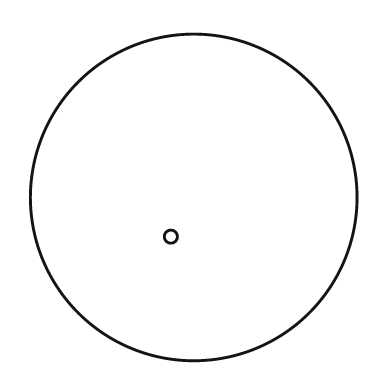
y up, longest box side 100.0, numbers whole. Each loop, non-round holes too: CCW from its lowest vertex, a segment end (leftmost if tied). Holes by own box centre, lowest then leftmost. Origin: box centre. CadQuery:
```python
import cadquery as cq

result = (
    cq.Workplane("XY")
    .moveTo(0.0, 0.0)
    .circle(50.0)
    .moveTo(-7.0, -12.0)
    .circle(2.0)
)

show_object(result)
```